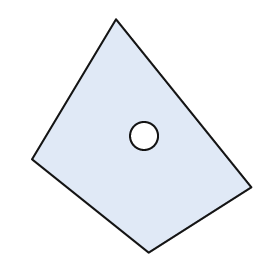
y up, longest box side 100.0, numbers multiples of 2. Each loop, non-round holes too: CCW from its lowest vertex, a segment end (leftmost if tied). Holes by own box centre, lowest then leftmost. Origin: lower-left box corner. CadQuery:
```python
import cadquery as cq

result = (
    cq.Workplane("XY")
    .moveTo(50.0, 0.0)
    .lineTo(94.0, 28.0)
    .lineTo(36.0, 100.0)
    .lineTo(0.0, 40.0)
    .close()
    .moveTo(48.0, 50.0)
    .circle(6.0)
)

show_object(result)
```